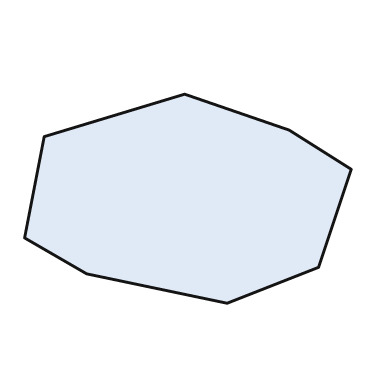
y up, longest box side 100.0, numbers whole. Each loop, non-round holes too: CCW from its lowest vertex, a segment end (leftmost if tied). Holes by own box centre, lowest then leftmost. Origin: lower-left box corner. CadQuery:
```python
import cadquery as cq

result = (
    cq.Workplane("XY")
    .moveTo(62.0, 0.0)
    .lineTo(90.0, 11.0)
    .lineTo(100.0, 41.0)
    .lineTo(81.0, 53.0)
    .lineTo(49.0, 64.0)
    .lineTo(6.0, 51.0)
    .lineTo(0.0, 20.0)
    .lineTo(19.0, 9.0)
    .close()
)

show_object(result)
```